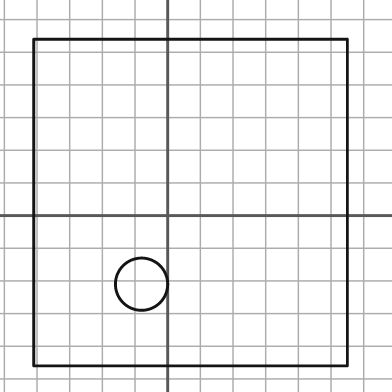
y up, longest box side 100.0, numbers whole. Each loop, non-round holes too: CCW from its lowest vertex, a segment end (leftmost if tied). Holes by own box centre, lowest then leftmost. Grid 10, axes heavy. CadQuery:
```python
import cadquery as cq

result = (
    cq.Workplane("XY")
    .moveTo(-41.0, -46.0)
    .lineTo(55.0, -46.0)
    .lineTo(55.0, 54.0)
    .lineTo(-41.0, 54.0)
    .close()
    .moveTo(-8.0, -21.0)
    .circle(8.0)
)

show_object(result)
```